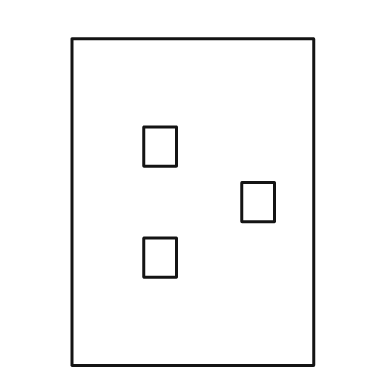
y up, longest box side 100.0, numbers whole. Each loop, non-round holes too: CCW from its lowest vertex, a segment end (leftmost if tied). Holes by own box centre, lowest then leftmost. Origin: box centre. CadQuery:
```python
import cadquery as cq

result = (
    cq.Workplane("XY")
    .moveTo(-37.0, -50.0)
    .lineTo(37.0, -50.0)
    .lineTo(37.0, 50.0)
    .lineTo(-37.0, 50.0)
    .close()
    .moveTo(-15.0, -23.0)
    .lineTo(-5.0, -23.0)
    .lineTo(-5.0, -11.0)
    .lineTo(-15.0, -11.0)
    .close()
    .moveTo(15.0, -6.0)
    .lineTo(25.0, -6.0)
    .lineTo(25.0, 6.0)
    .lineTo(15.0, 6.0)
    .close()
    .moveTo(-15.0, 11.0)
    .lineTo(-5.0, 11.0)
    .lineTo(-5.0, 23.0)
    .lineTo(-15.0, 23.0)
    .close()
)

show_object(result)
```